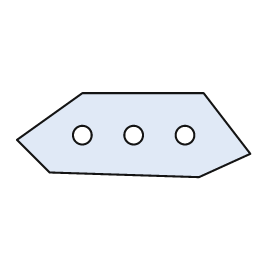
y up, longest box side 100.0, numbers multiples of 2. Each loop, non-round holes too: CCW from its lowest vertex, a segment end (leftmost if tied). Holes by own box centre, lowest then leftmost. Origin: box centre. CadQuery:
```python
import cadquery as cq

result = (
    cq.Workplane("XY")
    .moveTo(28.0, -18.0)
    .lineTo(50.0, -8.0)
    .lineTo(30.0, 18.0)
    .lineTo(-22.0, 18.0)
    .lineTo(-50.0, -2.0)
    .lineTo(-36.0, -16.0)
    .close()
    .moveTo(-22.0, 0.0)
    .circle(4.0)
    .moveTo(0.0, 0.0)
    .circle(4.0)
    .moveTo(22.0, 0.0)
    .circle(4.0)
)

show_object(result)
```